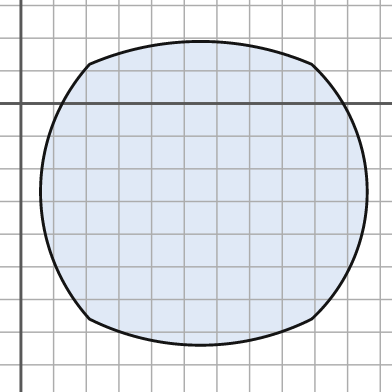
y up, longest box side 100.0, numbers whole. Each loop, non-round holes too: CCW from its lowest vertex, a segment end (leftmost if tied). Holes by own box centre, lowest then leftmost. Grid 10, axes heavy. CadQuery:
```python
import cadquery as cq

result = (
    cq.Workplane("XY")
    .moveTo(21.0, -66.0)
    .threePointArc((55.0, -74.0), (89.0, -66.0))
    .threePointArc((106.0, -27.0), (89.0, 12.0))
    .threePointArc((55.0, 19.0), (21.0, 12.0))
    .threePointArc((6.0, -27.0), (21.0, -66.0))
    .close()
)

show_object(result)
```